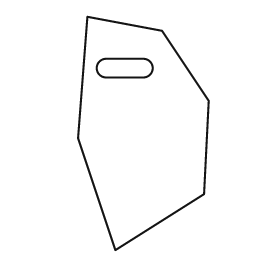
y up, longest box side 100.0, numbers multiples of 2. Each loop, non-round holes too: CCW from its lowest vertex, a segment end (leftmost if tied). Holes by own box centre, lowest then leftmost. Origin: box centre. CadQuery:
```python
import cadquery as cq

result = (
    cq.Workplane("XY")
    .moveTo(-12.0, -50.0)
    .lineTo(26.0, -26.0)
    .lineTo(28.0, 14.0)
    .lineTo(8.0, 44.0)
    .lineTo(-24.0, 50.0)
    .lineTo(-28.0, -2.0)
    .close()
    .moveTo(-16.0, 24.0)
    .lineTo(0.0, 24.0)
    .threePointArc((4.0, 28.0), (0.0, 32.0))
    .lineTo(-16.0, 32.0)
    .threePointArc((-20.0, 28.0), (-16.0, 24.0))
    .close()
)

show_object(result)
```